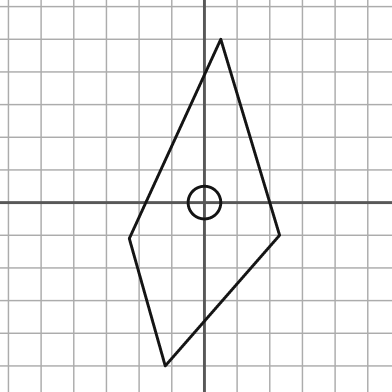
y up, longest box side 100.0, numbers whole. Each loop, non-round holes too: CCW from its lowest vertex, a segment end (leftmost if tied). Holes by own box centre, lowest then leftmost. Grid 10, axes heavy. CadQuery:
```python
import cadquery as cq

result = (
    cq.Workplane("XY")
    .moveTo(-12.0, -50.0)
    .lineTo(23.0, -10.0)
    .lineTo(5.0, 50.0)
    .lineTo(-23.0, -11.0)
    .close()
    .moveTo(0.0, 0.0)
    .circle(5.0)
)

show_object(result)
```